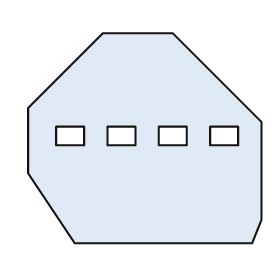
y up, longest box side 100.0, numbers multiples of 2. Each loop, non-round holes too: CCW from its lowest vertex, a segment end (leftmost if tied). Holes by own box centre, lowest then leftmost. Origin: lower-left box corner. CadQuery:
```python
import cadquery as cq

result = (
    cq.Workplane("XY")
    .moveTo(20.0, 0.0)
    .lineTo(96.0, 0.0)
    .lineTo(100.0, 10.0)
    .lineTo(100.0, 52.0)
    .lineTo(62.0, 90.0)
    .lineTo(32.0, 90.0)
    .lineTo(0.0, 58.0)
    .lineTo(0.0, 30.0)
    .close()
    .moveTo(12.0, 42.0)
    .lineTo(24.0, 42.0)
    .lineTo(24.0, 50.0)
    .lineTo(12.0, 50.0)
    .close()
    .moveTo(34.0, 42.0)
    .lineTo(46.0, 42.0)
    .lineTo(46.0, 50.0)
    .lineTo(34.0, 50.0)
    .close()
    .moveTo(56.0, 42.0)
    .lineTo(68.0, 42.0)
    .lineTo(68.0, 50.0)
    .lineTo(56.0, 50.0)
    .close()
    .moveTo(78.0, 42.0)
    .lineTo(90.0, 42.0)
    .lineTo(90.0, 50.0)
    .lineTo(78.0, 50.0)
    .close()
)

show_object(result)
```